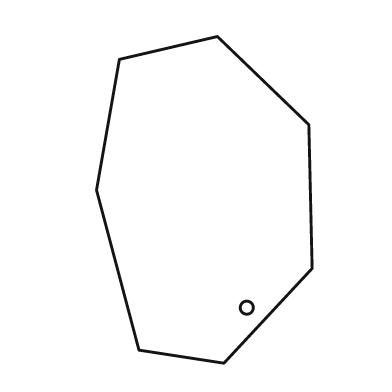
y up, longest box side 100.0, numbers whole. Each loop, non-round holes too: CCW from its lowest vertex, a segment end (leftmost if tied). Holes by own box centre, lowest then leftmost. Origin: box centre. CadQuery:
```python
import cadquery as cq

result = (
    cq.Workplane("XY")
    .moveTo(6.0, -50.0)
    .lineTo(33.0, -21.0)
    .lineTo(32.0, 23.0)
    .lineTo(4.0, 50.0)
    .lineTo(-26.0, 43.0)
    .lineTo(-33.0, 3.0)
    .lineTo(-20.0, -46.0)
    .close()
    .moveTo(13.0, -33.0)
    .circle(2.0)
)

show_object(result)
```